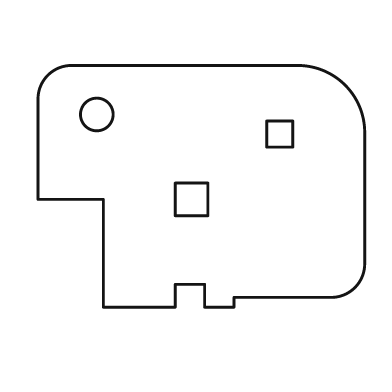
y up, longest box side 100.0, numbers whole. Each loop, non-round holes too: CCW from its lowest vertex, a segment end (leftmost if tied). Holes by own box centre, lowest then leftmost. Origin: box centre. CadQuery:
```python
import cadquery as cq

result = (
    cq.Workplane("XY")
    .moveTo(-30.0, -37.0)
    .lineTo(-8.0, -37.0)
    .lineTo(-8.0, -30.0)
    .lineTo(1.0, -30.0)
    .lineTo(1.0, -37.0)
    .lineTo(10.0, -37.0)
    .lineTo(10.0, -34.0)
    .lineTo(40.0, -34.0)
    .threePointArc((47.0, -31.0), (50.0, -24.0))
    .lineTo(50.0, 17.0)
    .threePointArc((44.0, 31.0), (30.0, 37.0))
    .lineTo(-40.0, 37.0)
    .threePointArc((-47.0, 34.0), (-50.0, 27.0))
    .lineTo(-50.0, -4.0)
    .lineTo(-30.0, -4.0)
    .close()
    .moveTo(-8.0, -9.0)
    .lineTo(2.0, -9.0)
    .lineTo(2.0, 1.0)
    .lineTo(-8.0, 1.0)
    .close()
    .moveTo(20.0, 12.0)
    .lineTo(28.0, 12.0)
    .lineTo(28.0, 20.0)
    .lineTo(20.0, 20.0)
    .close()
    .moveTo(-32.0, 22.0)
    .circle(5.0)
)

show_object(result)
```